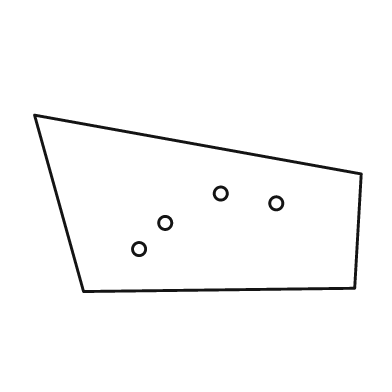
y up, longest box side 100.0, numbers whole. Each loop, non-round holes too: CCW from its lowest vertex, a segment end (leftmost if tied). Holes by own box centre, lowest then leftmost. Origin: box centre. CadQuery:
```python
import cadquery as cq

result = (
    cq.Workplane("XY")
    .moveTo(-35.0, -27.0)
    .lineTo(48.0, -26.0)
    .lineTo(50.0, 9.0)
    .lineTo(-50.0, 27.0)
    .close()
    .moveTo(-18.0, -14.0)
    .circle(2.0)
    .moveTo(-10.0, -6.0)
    .circle(2.0)
    .moveTo(24.0, 0.0)
    .circle(2.0)
    .moveTo(7.0, 3.0)
    .circle(2.0)
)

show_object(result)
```